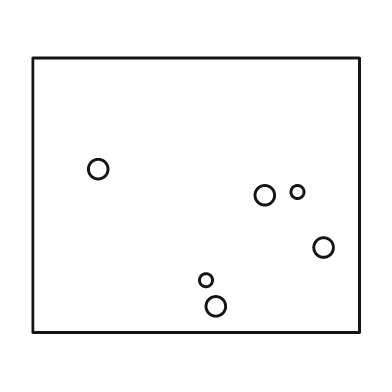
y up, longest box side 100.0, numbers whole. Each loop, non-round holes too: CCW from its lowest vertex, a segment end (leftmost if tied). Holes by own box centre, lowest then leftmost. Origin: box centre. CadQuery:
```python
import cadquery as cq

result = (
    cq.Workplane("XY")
    .moveTo(-50.0, -42.0)
    .lineTo(50.0, -42.0)
    .lineTo(50.0, 42.0)
    .lineTo(-50.0, 42.0)
    .close()
    .moveTo(6.0, -34.0)
    .circle(3.0)
    .moveTo(3.0, -26.0)
    .circle(2.0)
    .moveTo(39.0, -16.0)
    .circle(3.0)
    .moveTo(21.0, 0.0)
    .circle(3.0)
    .moveTo(31.0, 1.0)
    .circle(2.0)
    .moveTo(-30.0, 8.0)
    .circle(3.0)
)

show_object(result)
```